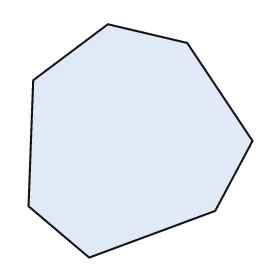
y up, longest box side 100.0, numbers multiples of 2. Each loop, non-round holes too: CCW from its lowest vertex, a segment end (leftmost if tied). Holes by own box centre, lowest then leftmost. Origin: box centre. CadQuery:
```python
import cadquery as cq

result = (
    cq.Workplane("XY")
    .moveTo(-22.0, -50.0)
    .lineTo(32.0, -30.0)
    .lineTo(48.0, 0.0)
    .lineTo(20.0, 42.0)
    .lineTo(-14.0, 50.0)
    .lineTo(-46.0, 26.0)
    .lineTo(-48.0, -28.0)
    .close()
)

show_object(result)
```